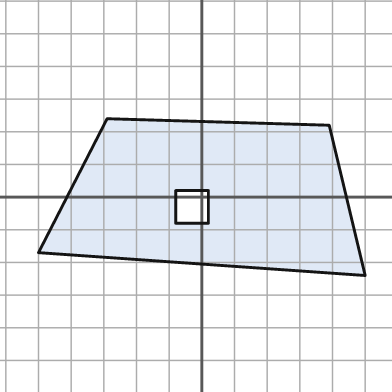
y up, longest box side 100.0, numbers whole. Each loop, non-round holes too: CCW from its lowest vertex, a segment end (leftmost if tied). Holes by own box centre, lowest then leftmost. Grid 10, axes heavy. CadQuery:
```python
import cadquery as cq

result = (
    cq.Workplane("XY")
    .moveTo(50.0, -24.0)
    .lineTo(39.0, 22.0)
    .lineTo(-29.0, 24.0)
    .lineTo(-50.0, -17.0)
    .close()
    .moveTo(-8.0, -8.0)
    .lineTo(2.0, -8.0)
    .lineTo(2.0, 2.0)
    .lineTo(-8.0, 2.0)
    .close()
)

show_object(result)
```